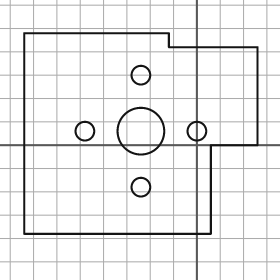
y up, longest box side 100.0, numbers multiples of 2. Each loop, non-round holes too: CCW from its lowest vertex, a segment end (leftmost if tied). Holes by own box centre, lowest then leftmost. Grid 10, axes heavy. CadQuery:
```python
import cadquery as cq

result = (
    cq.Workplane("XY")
    .moveTo(-74.0, -38.0)
    .lineTo(6.0, -38.0)
    .lineTo(6.0, 0.0)
    .lineTo(26.0, 0.0)
    .lineTo(26.0, 42.0)
    .lineTo(-12.0, 42.0)
    .lineTo(-12.0, 48.0)
    .lineTo(-74.0, 48.0)
    .close()
    .moveTo(-24.0, -18.0)
    .circle(4.0)
    .moveTo(-48.0, 6.0)
    .circle(4.0)
    .moveTo(-24.0, 6.0)
    .circle(10.0)
    .moveTo(0.0, 6.0)
    .circle(4.0)
    .moveTo(-24.0, 30.0)
    .circle(4.0)
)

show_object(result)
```